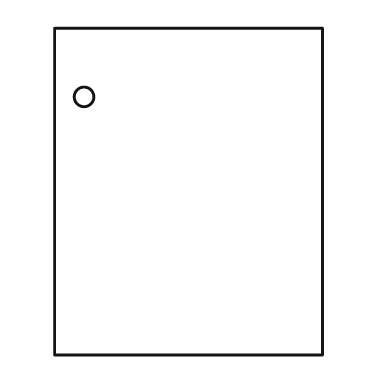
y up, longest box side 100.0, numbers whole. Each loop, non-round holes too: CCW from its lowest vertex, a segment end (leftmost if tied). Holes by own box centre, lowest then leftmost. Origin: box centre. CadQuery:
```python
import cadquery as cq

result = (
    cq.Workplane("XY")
    .moveTo(-41.0, -50.0)
    .lineTo(41.0, -50.0)
    .lineTo(41.0, 50.0)
    .lineTo(-41.0, 50.0)
    .close()
    .moveTo(-32.0, 29.0)
    .circle(3.0)
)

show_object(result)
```